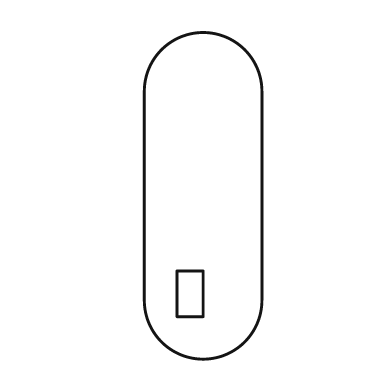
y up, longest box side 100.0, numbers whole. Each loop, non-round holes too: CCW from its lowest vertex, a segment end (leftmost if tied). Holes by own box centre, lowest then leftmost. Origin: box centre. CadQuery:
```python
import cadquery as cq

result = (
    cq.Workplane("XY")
    .moveTo(-18.0, -32.0)
    .threePointArc((0.0, -50.0), (18.0, -32.0))
    .lineTo(18.0, 32.0)
    .threePointArc((0.0, 50.0), (-18.0, 32.0))
    .close()
    .moveTo(-8.0, -37.0)
    .lineTo(0.0, -37.0)
    .lineTo(0.0, -23.0)
    .lineTo(-8.0, -23.0)
    .close()
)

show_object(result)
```